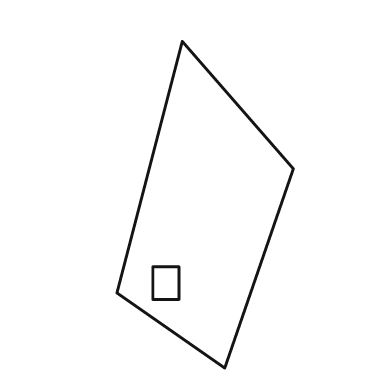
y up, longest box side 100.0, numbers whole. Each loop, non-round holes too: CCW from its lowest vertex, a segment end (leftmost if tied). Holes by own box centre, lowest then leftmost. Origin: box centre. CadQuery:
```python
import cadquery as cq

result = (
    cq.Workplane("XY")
    .moveTo(6.0, -50.0)
    .lineTo(27.0, 11.0)
    .lineTo(-7.0, 50.0)
    .lineTo(-27.0, -27.0)
    .close()
    .moveTo(-16.0, -29.0)
    .lineTo(-8.0, -29.0)
    .lineTo(-8.0, -19.0)
    .lineTo(-16.0, -19.0)
    .close()
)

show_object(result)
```